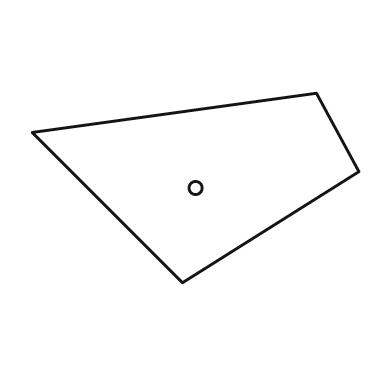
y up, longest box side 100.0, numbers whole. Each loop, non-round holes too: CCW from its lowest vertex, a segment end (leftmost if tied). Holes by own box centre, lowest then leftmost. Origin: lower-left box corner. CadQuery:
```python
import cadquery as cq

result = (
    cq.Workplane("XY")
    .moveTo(46.0, 0.0)
    .lineTo(100.0, 34.0)
    .lineTo(87.0, 58.0)
    .lineTo(0.0, 46.0)
    .close()
    .moveTo(50.0, 29.0)
    .circle(2.0)
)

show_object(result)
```